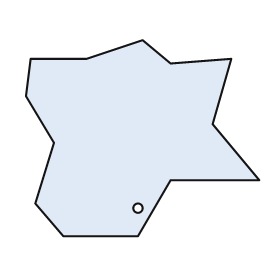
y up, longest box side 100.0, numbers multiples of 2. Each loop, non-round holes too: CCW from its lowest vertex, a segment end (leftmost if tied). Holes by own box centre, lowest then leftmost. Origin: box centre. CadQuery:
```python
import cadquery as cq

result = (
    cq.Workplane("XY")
    .moveTo(-34.0, -42.0)
    .lineTo(-2.0, -42.0)
    .lineTo(12.0, -18.0)
    .lineTo(50.0, -18.0)
    .lineTo(30.0, 6.0)
    .lineTo(38.0, 34.0)
    .lineTo(12.0, 32.0)
    .lineTo(0.0, 42.0)
    .lineTo(-24.0, 34.0)
    .lineTo(-48.0, 34.0)
    .lineTo(-50.0, 18.0)
    .lineTo(-38.0, -2.0)
    .lineTo(-46.0, -28.0)
    .close()
    .moveTo(-2.0, -30.0)
    .circle(2.0)
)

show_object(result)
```